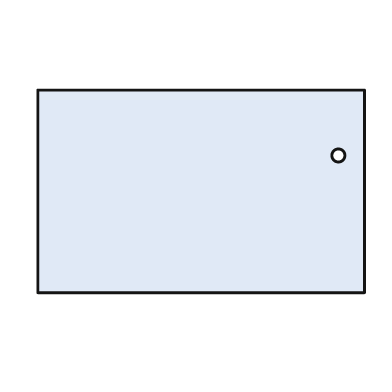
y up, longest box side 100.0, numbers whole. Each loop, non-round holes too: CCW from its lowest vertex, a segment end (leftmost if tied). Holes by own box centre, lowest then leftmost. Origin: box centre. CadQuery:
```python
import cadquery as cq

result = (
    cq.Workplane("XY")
    .moveTo(-50.0, -31.0)
    .lineTo(50.0, -31.0)
    .lineTo(50.0, 31.0)
    .lineTo(-50.0, 31.0)
    .close()
    .moveTo(42.0, 11.0)
    .circle(2.0)
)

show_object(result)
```